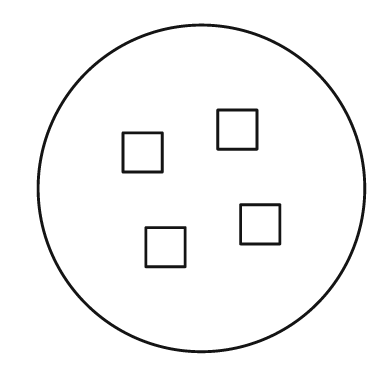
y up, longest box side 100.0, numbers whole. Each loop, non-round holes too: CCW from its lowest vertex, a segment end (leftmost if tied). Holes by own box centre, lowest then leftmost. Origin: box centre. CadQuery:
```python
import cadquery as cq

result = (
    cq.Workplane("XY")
    .moveTo(0.0, 0.0)
    .circle(50.0)
    .moveTo(-17.0, -24.0)
    .lineTo(-5.0, -24.0)
    .lineTo(-5.0, -12.0)
    .lineTo(-17.0, -12.0)
    .close()
    .moveTo(12.0, -17.0)
    .lineTo(24.0, -17.0)
    .lineTo(24.0, -5.0)
    .lineTo(12.0, -5.0)
    .close()
    .moveTo(-24.0, 5.0)
    .lineTo(-12.0, 5.0)
    .lineTo(-12.0, 17.0)
    .lineTo(-24.0, 17.0)
    .close()
    .moveTo(5.0, 12.0)
    .lineTo(17.0, 12.0)
    .lineTo(17.0, 24.0)
    .lineTo(5.0, 24.0)
    .close()
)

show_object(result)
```